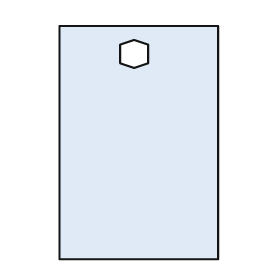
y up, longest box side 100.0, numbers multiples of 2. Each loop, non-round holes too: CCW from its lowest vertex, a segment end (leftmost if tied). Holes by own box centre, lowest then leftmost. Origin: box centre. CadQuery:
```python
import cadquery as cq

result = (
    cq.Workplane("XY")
    .moveTo(-34.0, -50.0)
    .lineTo(34.0, -50.0)
    .lineTo(34.0, 50.0)
    .lineTo(-34.0, 50.0)
    .close()
    .moveTo(-2.0, 32.0)
    .lineTo(4.0, 34.0)
    .lineTo(4.0, 42.0)
    .lineTo(-2.0, 44.0)
    .lineTo(-8.0, 42.0)
    .lineTo(-8.0, 34.0)
    .close()
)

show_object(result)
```